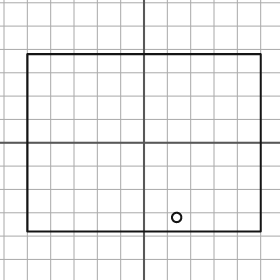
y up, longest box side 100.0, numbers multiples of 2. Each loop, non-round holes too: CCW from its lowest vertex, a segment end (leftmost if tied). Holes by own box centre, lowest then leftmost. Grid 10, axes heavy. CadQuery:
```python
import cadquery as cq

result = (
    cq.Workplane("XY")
    .moveTo(-50.0, -38.0)
    .lineTo(50.0, -38.0)
    .lineTo(50.0, 38.0)
    .lineTo(-50.0, 38.0)
    .close()
    .moveTo(14.0, -32.0)
    .circle(2.0)
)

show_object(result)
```